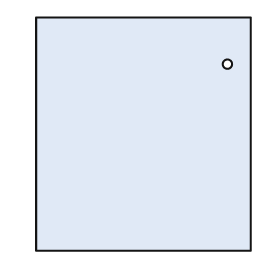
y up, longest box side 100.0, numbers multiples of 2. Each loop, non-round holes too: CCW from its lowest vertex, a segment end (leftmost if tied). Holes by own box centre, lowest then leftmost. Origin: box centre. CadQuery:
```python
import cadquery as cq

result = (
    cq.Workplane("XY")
    .moveTo(-46.0, -50.0)
    .lineTo(46.0, -50.0)
    .lineTo(46.0, 50.0)
    .lineTo(-46.0, 50.0)
    .close()
    .moveTo(36.0, 30.0)
    .circle(2.0)
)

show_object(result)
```